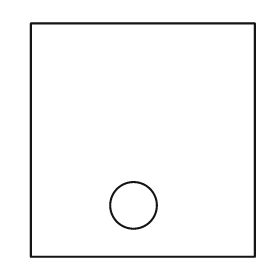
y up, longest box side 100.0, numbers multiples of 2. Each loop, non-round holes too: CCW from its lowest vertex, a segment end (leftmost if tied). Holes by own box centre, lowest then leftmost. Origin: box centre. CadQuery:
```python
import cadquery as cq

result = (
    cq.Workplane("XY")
    .moveTo(-48.0, -50.0)
    .lineTo(48.0, -50.0)
    .lineTo(48.0, 50.0)
    .lineTo(-48.0, 50.0)
    .close()
    .moveTo(-4.0, -28.0)
    .circle(10.0)
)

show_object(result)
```